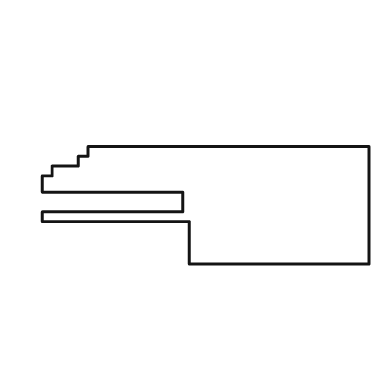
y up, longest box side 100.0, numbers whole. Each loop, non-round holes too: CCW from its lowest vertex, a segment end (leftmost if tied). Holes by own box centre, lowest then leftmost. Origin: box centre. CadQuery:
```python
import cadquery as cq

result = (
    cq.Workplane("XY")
    .moveTo(-5.0, -18.0)
    .lineTo(50.0, -18.0)
    .lineTo(50.0, 18.0)
    .lineTo(-36.0, 18.0)
    .lineTo(-36.0, 15.0)
    .lineTo(-39.0, 15.0)
    .lineTo(-39.0, 12.0)
    .lineTo(-47.0, 12.0)
    .lineTo(-47.0, 9.0)
    .lineTo(-50.0, 9.0)
    .lineTo(-50.0, 4.0)
    .lineTo(-7.0, 4.0)
    .lineTo(-7.0, -2.0)
    .lineTo(-50.0, -2.0)
    .lineTo(-50.0, -5.0)
    .lineTo(-5.0, -5.0)
    .close()
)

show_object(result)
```